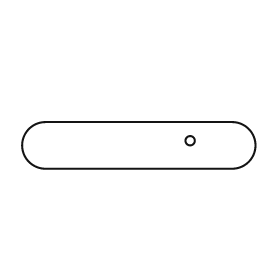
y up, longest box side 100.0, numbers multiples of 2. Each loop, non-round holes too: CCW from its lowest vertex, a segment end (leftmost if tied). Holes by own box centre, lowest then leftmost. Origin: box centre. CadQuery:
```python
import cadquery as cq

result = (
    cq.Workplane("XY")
    .moveTo(-40.0, -10.0)
    .lineTo(40.0, -10.0)
    .threePointArc((50.0, 0.0), (40.0, 10.0))
    .lineTo(-40.0, 10.0)
    .threePointArc((-50.0, 0.0), (-40.0, -10.0))
    .close()
    .moveTo(22.0, 2.0)
    .circle(2.0)
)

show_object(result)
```